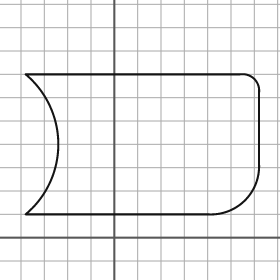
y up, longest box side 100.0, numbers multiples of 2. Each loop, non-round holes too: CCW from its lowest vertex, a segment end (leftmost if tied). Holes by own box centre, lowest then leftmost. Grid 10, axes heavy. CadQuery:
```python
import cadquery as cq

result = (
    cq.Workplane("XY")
    .moveTo(-38.0, 10.0)
    .lineTo(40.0, 10.0)
    .threePointArc((56.0, 16.0), (62.0, 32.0))
    .lineTo(62.0, 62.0)
    .threePointArc((60.0, 68.0), (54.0, 70.0))
    .lineTo(-38.0, 70.0)
    .threePointArc((-24.0, 40.0), (-38.0, 10.0))
    .close()
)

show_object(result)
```